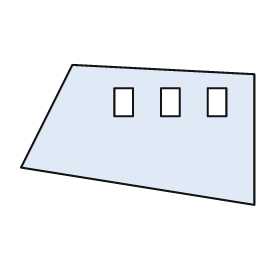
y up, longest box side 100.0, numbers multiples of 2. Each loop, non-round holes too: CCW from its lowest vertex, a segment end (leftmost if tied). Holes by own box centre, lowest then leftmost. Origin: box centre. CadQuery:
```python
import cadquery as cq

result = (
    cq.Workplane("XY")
    .moveTo(50.0, -30.0)
    .lineTo(50.0, 26.0)
    .lineTo(-28.0, 30.0)
    .lineTo(-50.0, -14.0)
    .close()
    .moveTo(-10.0, 8.0)
    .lineTo(-2.0, 8.0)
    .lineTo(-2.0, 20.0)
    .lineTo(-10.0, 20.0)
    .close()
    .moveTo(10.0, 8.0)
    .lineTo(18.0, 8.0)
    .lineTo(18.0, 20.0)
    .lineTo(10.0, 20.0)
    .close()
    .moveTo(30.0, 8.0)
    .lineTo(38.0, 8.0)
    .lineTo(38.0, 20.0)
    .lineTo(30.0, 20.0)
    .close()
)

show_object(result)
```